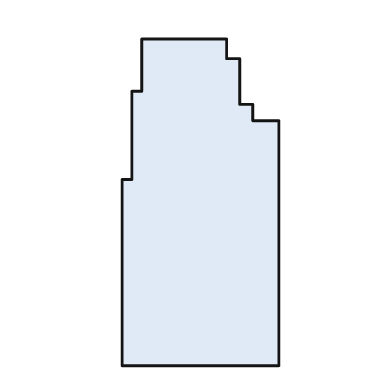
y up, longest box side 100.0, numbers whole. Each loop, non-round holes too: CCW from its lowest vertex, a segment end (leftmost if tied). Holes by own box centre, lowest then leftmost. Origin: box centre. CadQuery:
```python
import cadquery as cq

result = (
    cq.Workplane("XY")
    .moveTo(-24.0, -50.0)
    .lineTo(24.0, -50.0)
    .lineTo(24.0, 25.0)
    .lineTo(16.0, 25.0)
    .lineTo(16.0, 30.0)
    .lineTo(12.0, 30.0)
    .lineTo(12.0, 44.0)
    .lineTo(8.0, 44.0)
    .lineTo(8.0, 50.0)
    .lineTo(-18.0, 50.0)
    .lineTo(-18.0, 34.0)
    .lineTo(-21.0, 34.0)
    .lineTo(-21.0, 7.0)
    .lineTo(-24.0, 7.0)
    .close()
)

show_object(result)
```